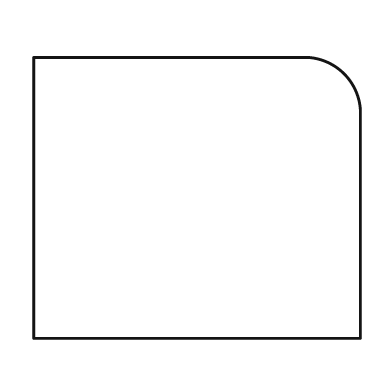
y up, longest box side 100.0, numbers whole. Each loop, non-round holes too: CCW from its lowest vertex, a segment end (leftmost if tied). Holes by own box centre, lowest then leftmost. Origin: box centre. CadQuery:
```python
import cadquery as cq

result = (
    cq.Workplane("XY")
    .moveTo(-50.0, -43.0)
    .lineTo(50.0, -43.0)
    .lineTo(50.0, 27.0)
    .threePointArc((45.0, 38.0), (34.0, 43.0))
    .lineTo(-50.0, 43.0)
    .close()
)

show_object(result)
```